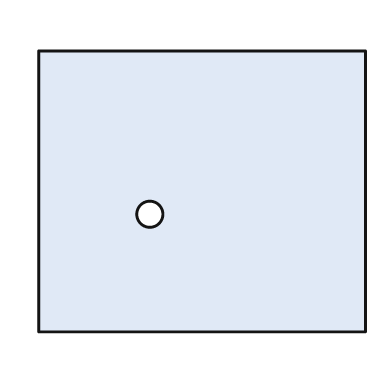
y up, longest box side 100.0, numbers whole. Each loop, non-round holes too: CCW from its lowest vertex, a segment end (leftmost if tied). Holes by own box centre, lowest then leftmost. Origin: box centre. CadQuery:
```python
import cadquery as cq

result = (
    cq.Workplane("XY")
    .moveTo(-50.0, -43.0)
    .lineTo(50.0, -43.0)
    .lineTo(50.0, 43.0)
    .lineTo(-50.0, 43.0)
    .close()
    .moveTo(-16.0, -7.0)
    .circle(4.0)
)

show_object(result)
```